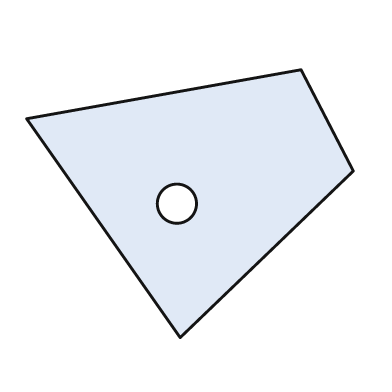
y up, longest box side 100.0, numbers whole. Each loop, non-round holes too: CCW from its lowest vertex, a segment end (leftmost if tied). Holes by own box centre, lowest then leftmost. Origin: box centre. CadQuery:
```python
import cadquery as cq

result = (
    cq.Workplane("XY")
    .moveTo(-3.0, -41.0)
    .lineTo(50.0, 10.0)
    .lineTo(34.0, 41.0)
    .lineTo(-50.0, 26.0)
    .close()
    .moveTo(-4.0, 0.0)
    .circle(6.0)
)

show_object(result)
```